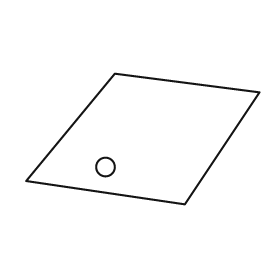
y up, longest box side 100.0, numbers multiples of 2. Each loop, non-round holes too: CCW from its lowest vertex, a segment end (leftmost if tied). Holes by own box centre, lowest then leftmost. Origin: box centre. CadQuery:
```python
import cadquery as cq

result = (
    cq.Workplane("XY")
    .moveTo(18.0, -28.0)
    .lineTo(50.0, 20.0)
    .lineTo(-12.0, 28.0)
    .lineTo(-50.0, -18.0)
    .close()
    .moveTo(-16.0, -12.0)
    .circle(4.0)
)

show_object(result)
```